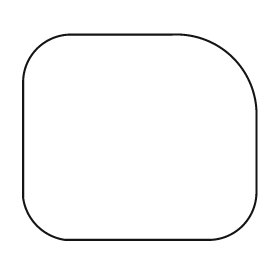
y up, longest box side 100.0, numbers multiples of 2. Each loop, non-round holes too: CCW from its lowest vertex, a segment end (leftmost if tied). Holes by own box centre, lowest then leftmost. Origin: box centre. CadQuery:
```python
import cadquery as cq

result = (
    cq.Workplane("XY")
    .moveTo(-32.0, -44.0)
    .lineTo(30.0, -44.0)
    .threePointArc((44.0, -38.0), (50.0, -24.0))
    .lineTo(50.0, 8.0)
    .threePointArc((40.0, 34.0), (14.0, 44.0))
    .lineTo(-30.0, 44.0)
    .threePointArc((-44.0, 38.0), (-50.0, 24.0))
    .lineTo(-50.0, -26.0)
    .threePointArc((-44.0, -38.0), (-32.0, -44.0))
    .close()
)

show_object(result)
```